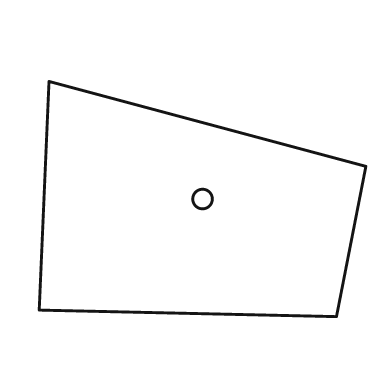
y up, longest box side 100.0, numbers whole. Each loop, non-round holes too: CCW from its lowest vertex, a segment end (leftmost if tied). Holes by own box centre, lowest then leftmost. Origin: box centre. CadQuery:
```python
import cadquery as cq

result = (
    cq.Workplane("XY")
    .moveTo(41.0, -36.0)
    .lineTo(50.0, 10.0)
    .lineTo(-47.0, 36.0)
    .lineTo(-50.0, -34.0)
    .close()
    .moveTo(0.0, 0.0)
    .circle(3.0)
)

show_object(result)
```